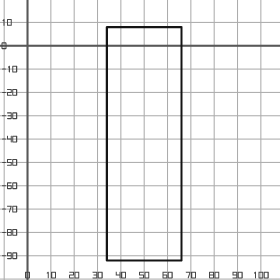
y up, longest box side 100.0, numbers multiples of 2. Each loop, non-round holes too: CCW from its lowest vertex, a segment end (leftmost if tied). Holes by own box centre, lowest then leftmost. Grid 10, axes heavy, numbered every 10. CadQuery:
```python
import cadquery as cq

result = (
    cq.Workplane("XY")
    .moveTo(34.0, -92.0)
    .lineTo(66.0, -92.0)
    .lineTo(66.0, 8.0)
    .lineTo(34.0, 8.0)
    .close()
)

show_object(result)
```